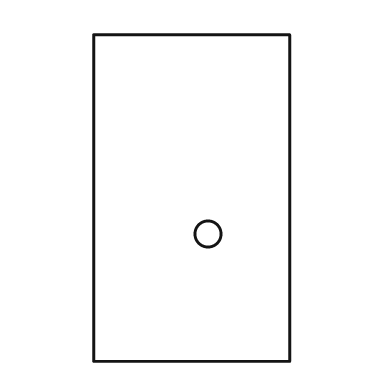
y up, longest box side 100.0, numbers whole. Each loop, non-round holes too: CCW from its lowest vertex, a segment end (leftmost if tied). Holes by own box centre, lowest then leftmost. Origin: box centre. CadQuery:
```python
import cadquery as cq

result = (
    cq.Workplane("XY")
    .moveTo(-30.0, -50.0)
    .lineTo(30.0, -50.0)
    .lineTo(30.0, 50.0)
    .lineTo(-30.0, 50.0)
    .close()
    .moveTo(5.0, -11.0)
    .circle(4.0)
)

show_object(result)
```